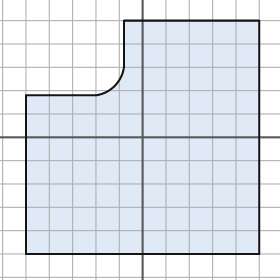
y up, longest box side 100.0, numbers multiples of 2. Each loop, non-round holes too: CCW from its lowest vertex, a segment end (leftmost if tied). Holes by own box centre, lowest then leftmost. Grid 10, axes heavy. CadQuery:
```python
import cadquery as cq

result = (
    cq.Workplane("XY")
    .moveTo(-50.0, -50.0)
    .lineTo(50.0, -50.0)
    .lineTo(50.0, 50.0)
    .lineTo(-8.0, 50.0)
    .lineTo(-8.0, 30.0)
    .threePointArc((-12.0, 22.0), (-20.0, 18.0))
    .lineTo(-50.0, 18.0)
    .close()
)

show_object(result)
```